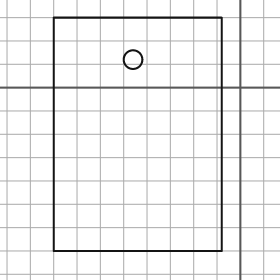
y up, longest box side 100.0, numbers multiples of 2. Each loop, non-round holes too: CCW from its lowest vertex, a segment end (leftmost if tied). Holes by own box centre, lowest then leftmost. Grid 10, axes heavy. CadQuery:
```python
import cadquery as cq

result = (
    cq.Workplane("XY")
    .moveTo(-80.0, -70.0)
    .lineTo(-8.0, -70.0)
    .lineTo(-8.0, 30.0)
    .lineTo(-80.0, 30.0)
    .close()
    .moveTo(-46.0, 12.0)
    .circle(4.0)
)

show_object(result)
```